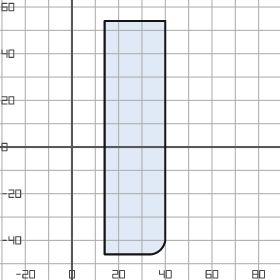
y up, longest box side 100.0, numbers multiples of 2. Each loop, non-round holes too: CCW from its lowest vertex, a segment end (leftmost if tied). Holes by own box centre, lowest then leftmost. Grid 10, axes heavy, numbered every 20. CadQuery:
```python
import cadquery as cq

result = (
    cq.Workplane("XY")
    .moveTo(14.0, -46.0)
    .lineTo(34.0, -46.0)
    .threePointArc((38.0, -44.0), (40.0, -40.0))
    .lineTo(40.0, 54.0)
    .lineTo(14.0, 54.0)
    .close()
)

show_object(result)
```